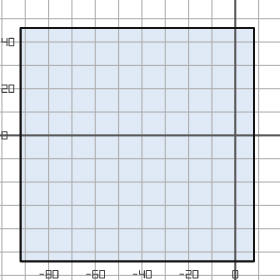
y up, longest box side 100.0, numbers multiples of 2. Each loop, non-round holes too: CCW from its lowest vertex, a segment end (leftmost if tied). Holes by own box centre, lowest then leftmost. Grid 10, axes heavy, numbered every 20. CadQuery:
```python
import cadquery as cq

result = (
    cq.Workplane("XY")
    .moveTo(-92.0, -54.0)
    .lineTo(8.0, -54.0)
    .lineTo(8.0, 46.0)
    .lineTo(-92.0, 46.0)
    .close()
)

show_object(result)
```